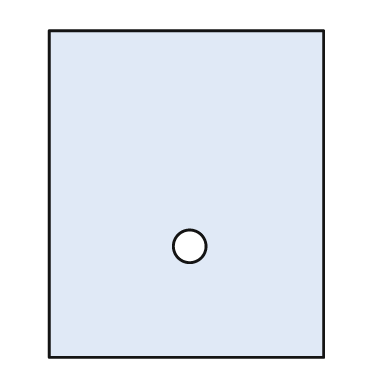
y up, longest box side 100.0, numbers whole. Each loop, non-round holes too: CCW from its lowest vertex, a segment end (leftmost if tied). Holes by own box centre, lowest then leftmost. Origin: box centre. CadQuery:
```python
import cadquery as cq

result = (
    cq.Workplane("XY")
    .moveTo(-42.0, -50.0)
    .lineTo(42.0, -50.0)
    .lineTo(42.0, 50.0)
    .lineTo(-42.0, 50.0)
    .close()
    .moveTo(1.0, -16.0)
    .circle(5.0)
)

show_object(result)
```